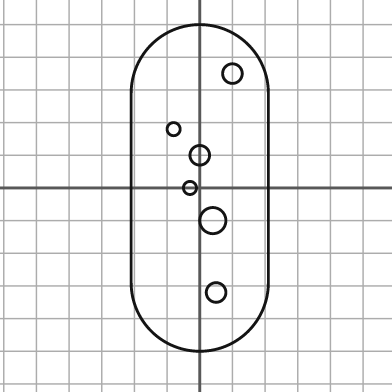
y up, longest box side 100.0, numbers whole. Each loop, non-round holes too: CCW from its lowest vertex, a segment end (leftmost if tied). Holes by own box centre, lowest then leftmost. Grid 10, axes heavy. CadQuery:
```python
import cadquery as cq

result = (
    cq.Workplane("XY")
    .moveTo(-21.0, -29.0)
    .threePointArc((0.0, -50.0), (21.0, -29.0))
    .lineTo(21.0, 29.0)
    .threePointArc((0.0, 50.0), (-21.0, 29.0))
    .close()
    .moveTo(5.0, -32.0)
    .circle(3.0)
    .moveTo(4.0, -10.0)
    .circle(4.0)
    .moveTo(-3.0, 0.0)
    .circle(2.0)
    .moveTo(0.0, 10.0)
    .circle(3.0)
    .moveTo(-8.0, 18.0)
    .circle(2.0)
    .moveTo(10.0, 35.0)
    .circle(3.0)
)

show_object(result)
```